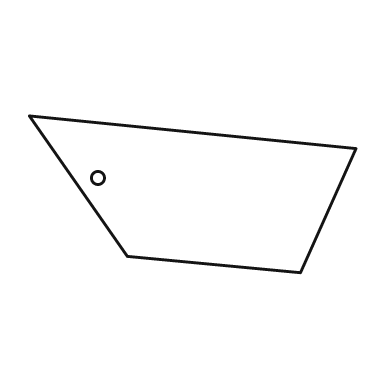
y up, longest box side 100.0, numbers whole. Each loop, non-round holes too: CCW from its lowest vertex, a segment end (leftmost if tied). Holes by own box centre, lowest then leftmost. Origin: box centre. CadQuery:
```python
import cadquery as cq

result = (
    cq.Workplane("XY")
    .moveTo(33.0, -24.0)
    .lineTo(50.0, 14.0)
    .lineTo(-50.0, 24.0)
    .lineTo(-20.0, -19.0)
    .close()
    .moveTo(-29.0, 5.0)
    .circle(2.0)
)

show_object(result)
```